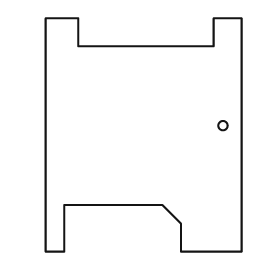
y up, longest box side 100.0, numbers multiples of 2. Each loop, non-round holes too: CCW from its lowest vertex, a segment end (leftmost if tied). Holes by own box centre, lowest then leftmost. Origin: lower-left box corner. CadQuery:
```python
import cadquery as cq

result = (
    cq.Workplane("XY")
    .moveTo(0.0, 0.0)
    .lineTo(8.0, 0.0)
    .lineTo(8.0, 20.0)
    .lineTo(50.0, 20.0)
    .lineTo(58.0, 12.0)
    .lineTo(58.0, 0.0)
    .lineTo(84.0, 0.0)
    .lineTo(84.0, 100.0)
    .lineTo(72.0, 100.0)
    .lineTo(72.0, 88.0)
    .lineTo(14.0, 88.0)
    .lineTo(14.0, 100.0)
    .lineTo(0.0, 100.0)
    .close()
    .moveTo(76.0, 54.0)
    .circle(2.0)
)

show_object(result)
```